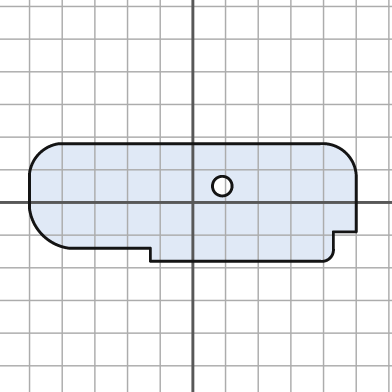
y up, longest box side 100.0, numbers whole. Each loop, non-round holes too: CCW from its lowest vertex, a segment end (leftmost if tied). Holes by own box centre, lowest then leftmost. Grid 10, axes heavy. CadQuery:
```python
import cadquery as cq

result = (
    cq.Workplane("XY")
    .moveTo(-13.0, -18.0)
    .lineTo(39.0, -18.0)
    .threePointArc((42.0, -17.0), (43.0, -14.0))
    .lineTo(43.0, -9.0)
    .lineTo(50.0, -9.0)
    .lineTo(50.0, 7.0)
    .threePointArc((47.0, 15.0), (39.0, 18.0))
    .lineTo(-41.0, 18.0)
    .threePointArc((-47.0, 15.0), (-50.0, 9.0))
    .lineTo(-50.0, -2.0)
    .threePointArc((-46.0, -10.0), (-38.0, -14.0))
    .lineTo(-13.0, -14.0)
    .close()
    .moveTo(9.0, 5.0)
    .circle(3.0)
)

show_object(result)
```